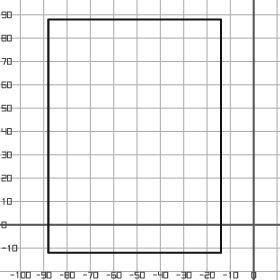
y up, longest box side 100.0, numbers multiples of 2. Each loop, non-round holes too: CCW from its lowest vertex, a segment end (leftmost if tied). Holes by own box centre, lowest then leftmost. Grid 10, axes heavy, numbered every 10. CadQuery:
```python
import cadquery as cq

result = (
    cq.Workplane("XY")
    .moveTo(-88.0, -12.0)
    .lineTo(-14.0, -12.0)
    .lineTo(-14.0, 88.0)
    .lineTo(-88.0, 88.0)
    .close()
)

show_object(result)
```